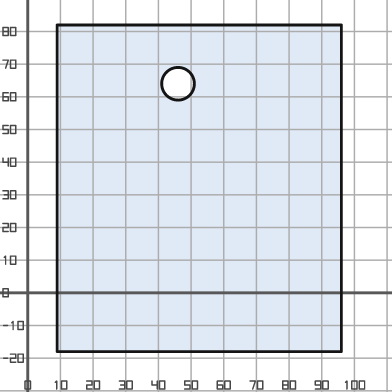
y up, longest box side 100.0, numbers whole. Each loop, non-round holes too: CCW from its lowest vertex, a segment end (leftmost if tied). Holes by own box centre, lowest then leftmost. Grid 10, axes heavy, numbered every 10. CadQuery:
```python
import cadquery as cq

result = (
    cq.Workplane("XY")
    .moveTo(9.0, -18.0)
    .lineTo(96.0, -18.0)
    .lineTo(96.0, 82.0)
    .lineTo(9.0, 82.0)
    .close()
    .moveTo(46.0, 64.0)
    .circle(5.0)
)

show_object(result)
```